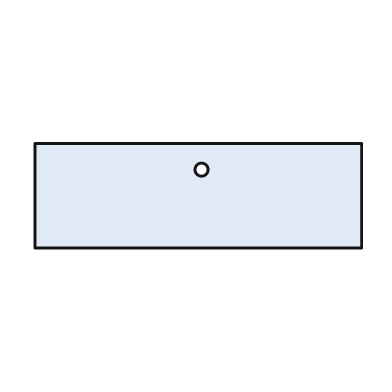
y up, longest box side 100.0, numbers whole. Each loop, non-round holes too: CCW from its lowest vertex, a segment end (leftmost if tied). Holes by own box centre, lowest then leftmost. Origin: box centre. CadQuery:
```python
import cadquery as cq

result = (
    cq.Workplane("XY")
    .moveTo(-50.0, -16.0)
    .lineTo(50.0, -16.0)
    .lineTo(50.0, 16.0)
    .lineTo(-50.0, 16.0)
    .close()
    .moveTo(1.0, 8.0)
    .circle(2.0)
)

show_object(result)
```